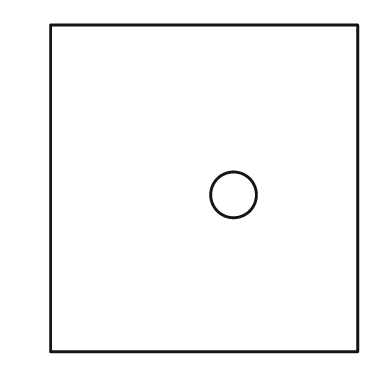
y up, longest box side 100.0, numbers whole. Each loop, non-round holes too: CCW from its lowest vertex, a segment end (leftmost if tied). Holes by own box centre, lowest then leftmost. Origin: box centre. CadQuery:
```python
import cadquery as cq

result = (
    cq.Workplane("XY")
    .moveTo(-47.0, -50.0)
    .lineTo(47.0, -50.0)
    .lineTo(47.0, 50.0)
    .lineTo(-47.0, 50.0)
    .close()
    .moveTo(9.0, -2.0)
    .circle(7.0)
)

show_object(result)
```